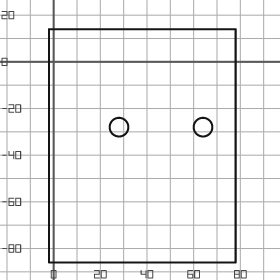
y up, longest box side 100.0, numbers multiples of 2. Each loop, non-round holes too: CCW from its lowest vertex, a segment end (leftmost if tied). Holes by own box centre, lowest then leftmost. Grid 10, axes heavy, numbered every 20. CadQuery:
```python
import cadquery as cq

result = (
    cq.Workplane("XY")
    .moveTo(-2.0, -86.0)
    .lineTo(78.0, -86.0)
    .lineTo(78.0, 14.0)
    .lineTo(-2.0, 14.0)
    .close()
    .moveTo(28.0, -28.0)
    .circle(4.0)
    .moveTo(64.0, -28.0)
    .circle(4.0)
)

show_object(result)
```